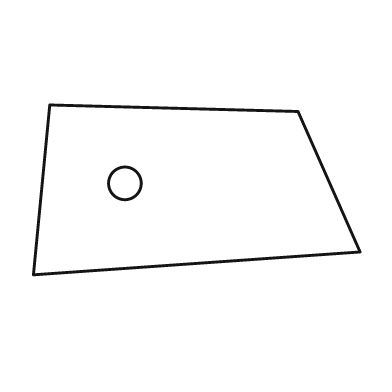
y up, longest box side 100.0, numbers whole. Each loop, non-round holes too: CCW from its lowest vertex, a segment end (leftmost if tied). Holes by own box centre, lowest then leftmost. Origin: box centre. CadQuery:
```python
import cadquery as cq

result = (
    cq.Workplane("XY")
    .moveTo(-50.0, -26.0)
    .lineTo(50.0, -19.0)
    .lineTo(31.0, 24.0)
    .lineTo(-45.0, 26.0)
    .close()
    .moveTo(-22.0, 2.0)
    .circle(5.0)
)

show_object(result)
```